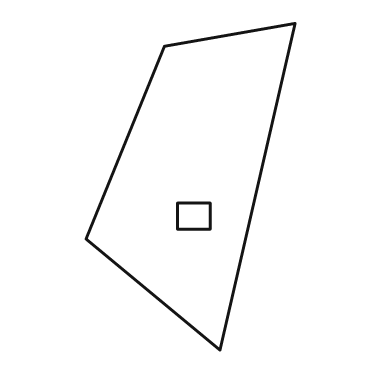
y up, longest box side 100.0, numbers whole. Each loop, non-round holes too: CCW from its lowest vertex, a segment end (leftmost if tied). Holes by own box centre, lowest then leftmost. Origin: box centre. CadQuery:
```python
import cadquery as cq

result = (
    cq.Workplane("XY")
    .moveTo(9.0, -50.0)
    .lineTo(32.0, 50.0)
    .lineTo(-8.0, 43.0)
    .lineTo(-32.0, -16.0)
    .close()
    .moveTo(-4.0, -13.0)
    .lineTo(6.0, -13.0)
    .lineTo(6.0, -5.0)
    .lineTo(-4.0, -5.0)
    .close()
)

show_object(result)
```